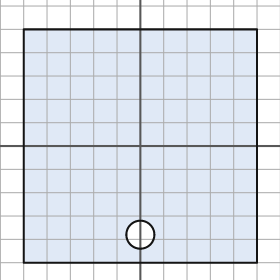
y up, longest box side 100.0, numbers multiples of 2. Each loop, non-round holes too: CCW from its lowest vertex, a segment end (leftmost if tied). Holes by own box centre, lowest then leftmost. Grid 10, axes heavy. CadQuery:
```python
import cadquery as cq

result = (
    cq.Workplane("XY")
    .moveTo(-50.0, -50.0)
    .lineTo(50.0, -50.0)
    .lineTo(50.0, 50.0)
    .lineTo(-50.0, 50.0)
    .close()
    .moveTo(0.0, -38.0)
    .circle(6.0)
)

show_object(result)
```